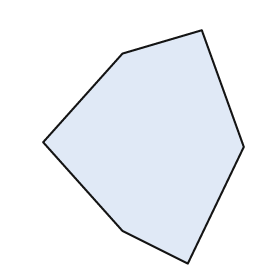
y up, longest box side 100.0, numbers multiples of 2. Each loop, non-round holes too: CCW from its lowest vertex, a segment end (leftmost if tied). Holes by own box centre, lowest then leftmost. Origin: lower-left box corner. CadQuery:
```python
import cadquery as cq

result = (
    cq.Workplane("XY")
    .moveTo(62.0, 0.0)
    .lineTo(86.0, 50.0)
    .lineTo(68.0, 100.0)
    .lineTo(34.0, 90.0)
    .lineTo(0.0, 52.0)
    .lineTo(34.0, 14.0)
    .close()
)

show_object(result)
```